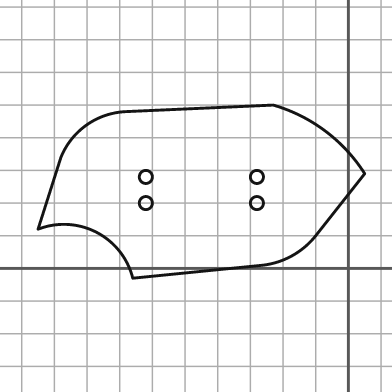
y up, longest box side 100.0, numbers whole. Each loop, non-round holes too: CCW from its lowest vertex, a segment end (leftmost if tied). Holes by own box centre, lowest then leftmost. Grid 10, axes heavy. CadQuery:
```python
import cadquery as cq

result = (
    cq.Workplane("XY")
    .moveTo(-66.0, -3.0)
    .lineTo(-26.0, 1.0)
    .threePointArc((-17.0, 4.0), (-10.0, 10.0))
    .lineTo(5.0, 29.0)
    .threePointArc((-7.0, 42.0), (-23.0, 50.0))
    .lineTo(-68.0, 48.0)
    .threePointArc((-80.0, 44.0), (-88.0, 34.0))
    .lineTo(-95.0, 12.0)
    .threePointArc((-77.0, 11.0), (-66.0, -3.0))
    .close()
    .moveTo(-62.0, 20.0)
    .circle(2.0)
    .moveTo(-28.0, 20.0)
    .circle(2.0)
    .moveTo(-62.0, 28.0)
    .circle(2.0)
    .moveTo(-28.0, 28.0)
    .circle(2.0)
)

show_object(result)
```